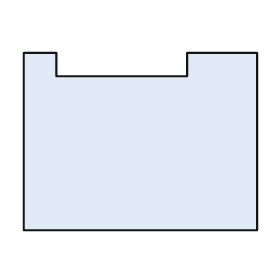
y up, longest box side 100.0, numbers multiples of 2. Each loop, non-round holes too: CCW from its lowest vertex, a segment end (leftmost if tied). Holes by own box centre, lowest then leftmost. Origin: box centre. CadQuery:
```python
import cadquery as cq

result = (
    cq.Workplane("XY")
    .moveTo(-50.0, -38.0)
    .lineTo(50.0, -38.0)
    .lineTo(50.0, 38.0)
    .lineTo(20.0, 38.0)
    .lineTo(20.0, 28.0)
    .lineTo(-36.0, 28.0)
    .lineTo(-36.0, 38.0)
    .lineTo(-50.0, 38.0)
    .close()
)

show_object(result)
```